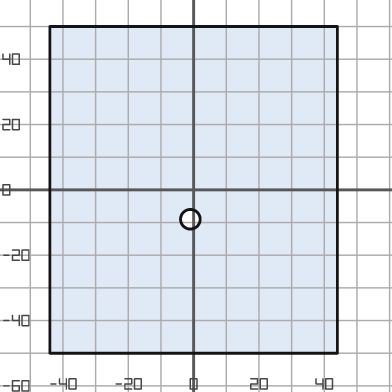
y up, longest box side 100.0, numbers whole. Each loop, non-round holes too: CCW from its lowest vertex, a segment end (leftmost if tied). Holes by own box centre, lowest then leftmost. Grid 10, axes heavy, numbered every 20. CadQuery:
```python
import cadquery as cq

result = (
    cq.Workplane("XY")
    .moveTo(-44.0, -50.0)
    .lineTo(44.0, -50.0)
    .lineTo(44.0, 50.0)
    .lineTo(-44.0, 50.0)
    .close()
    .moveTo(-1.0, -9.0)
    .circle(3.0)
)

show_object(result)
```